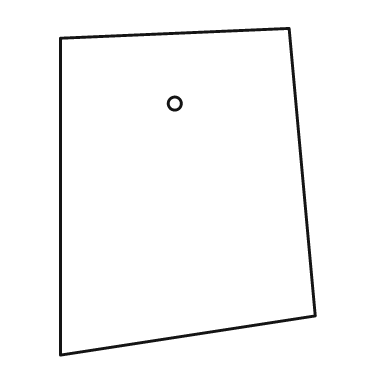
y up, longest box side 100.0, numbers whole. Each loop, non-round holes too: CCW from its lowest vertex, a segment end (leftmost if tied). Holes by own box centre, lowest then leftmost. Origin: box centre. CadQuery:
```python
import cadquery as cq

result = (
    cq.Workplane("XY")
    .moveTo(-39.0, -50.0)
    .lineTo(39.0, -38.0)
    .lineTo(31.0, 50.0)
    .lineTo(-39.0, 47.0)
    .close()
    .moveTo(-4.0, 27.0)
    .circle(2.0)
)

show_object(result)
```